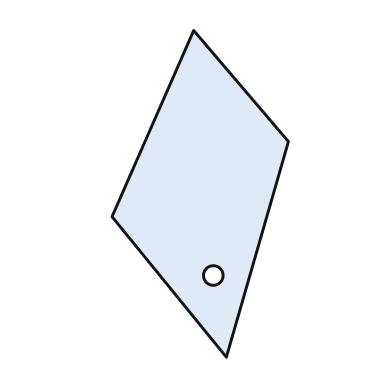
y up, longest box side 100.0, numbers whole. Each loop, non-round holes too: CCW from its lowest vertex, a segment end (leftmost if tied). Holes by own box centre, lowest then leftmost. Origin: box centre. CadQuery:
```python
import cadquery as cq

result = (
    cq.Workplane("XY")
    .moveTo(8.0, -50.0)
    .lineTo(27.0, 16.0)
    .lineTo(-2.0, 50.0)
    .lineTo(-27.0, -7.0)
    .close()
    .moveTo(4.0, -25.0)
    .circle(3.0)
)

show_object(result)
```